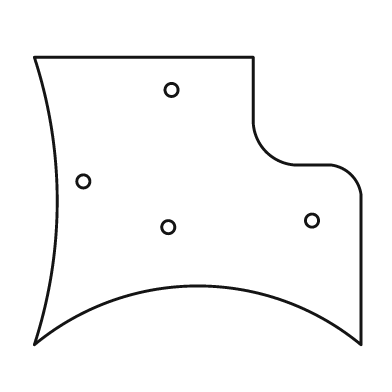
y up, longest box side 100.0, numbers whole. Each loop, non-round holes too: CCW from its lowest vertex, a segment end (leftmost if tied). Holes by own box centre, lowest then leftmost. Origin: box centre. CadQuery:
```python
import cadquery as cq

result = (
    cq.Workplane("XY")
    .moveTo(-50.0, -44.0)
    .threePointArc((0.0, -26.0), (50.0, -44.0))
    .lineTo(50.0, 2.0)
    .threePointArc((47.0, 8.0), (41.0, 11.0))
    .lineTo(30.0, 11.0)
    .threePointArc((21.0, 15.0), (17.0, 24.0))
    .lineTo(17.0, 44.0)
    .lineTo(-50.0, 44.0)
    .threePointArc((-43.0, 0.0), (-50.0, -44.0))
    .close()
    .moveTo(-9.0, -8.0)
    .circle(2.0)
    .moveTo(35.0, -6.0)
    .circle(2.0)
    .moveTo(-35.0, 6.0)
    .circle(2.0)
    .moveTo(-8.0, 34.0)
    .circle(2.0)
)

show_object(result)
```